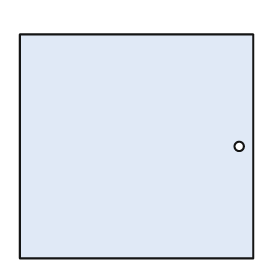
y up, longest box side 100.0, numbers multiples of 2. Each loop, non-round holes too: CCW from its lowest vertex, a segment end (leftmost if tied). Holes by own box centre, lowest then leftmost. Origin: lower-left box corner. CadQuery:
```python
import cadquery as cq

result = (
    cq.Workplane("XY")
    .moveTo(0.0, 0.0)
    .lineTo(100.0, 0.0)
    .lineTo(100.0, 96.0)
    .lineTo(0.0, 96.0)
    .close()
    .moveTo(94.0, 48.0)
    .circle(2.0)
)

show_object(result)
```